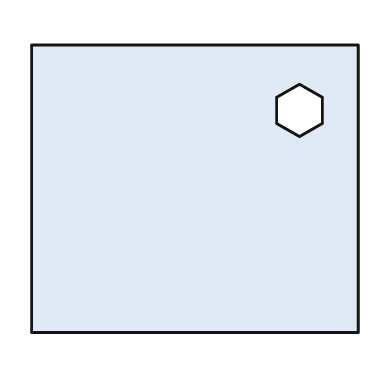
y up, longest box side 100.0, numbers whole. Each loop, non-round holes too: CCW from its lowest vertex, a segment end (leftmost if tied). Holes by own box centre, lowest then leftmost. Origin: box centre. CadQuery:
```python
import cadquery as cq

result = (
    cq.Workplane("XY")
    .moveTo(-50.0, -44.0)
    .lineTo(50.0, -44.0)
    .lineTo(50.0, 44.0)
    .lineTo(-50.0, 44.0)
    .close()
    .moveTo(32.0, 16.0)
    .lineTo(39.0, 20.0)
    .lineTo(39.0, 28.0)
    .lineTo(32.0, 32.0)
    .lineTo(25.0, 28.0)
    .lineTo(25.0, 20.0)
    .close()
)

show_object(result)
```